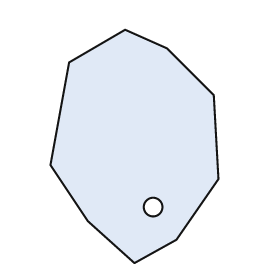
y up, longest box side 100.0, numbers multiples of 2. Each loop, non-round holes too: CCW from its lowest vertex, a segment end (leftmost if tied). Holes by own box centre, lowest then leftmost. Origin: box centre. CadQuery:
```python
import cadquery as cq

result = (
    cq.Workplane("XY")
    .moveTo(0.0, -50.0)
    .lineTo(18.0, -40.0)
    .lineTo(36.0, -14.0)
    .lineTo(34.0, 22.0)
    .lineTo(14.0, 42.0)
    .lineTo(-4.0, 50.0)
    .lineTo(-28.0, 36.0)
    .lineTo(-36.0, -8.0)
    .lineTo(-20.0, -32.0)
    .close()
    .moveTo(8.0, -26.0)
    .circle(4.0)
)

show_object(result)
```